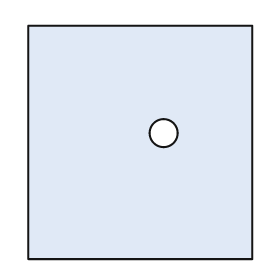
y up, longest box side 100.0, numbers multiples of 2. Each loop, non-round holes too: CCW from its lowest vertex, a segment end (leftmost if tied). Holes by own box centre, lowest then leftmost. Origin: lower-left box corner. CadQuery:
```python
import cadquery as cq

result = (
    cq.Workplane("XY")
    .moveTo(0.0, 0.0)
    .lineTo(96.0, 0.0)
    .lineTo(96.0, 100.0)
    .lineTo(0.0, 100.0)
    .close()
    .moveTo(58.0, 54.0)
    .circle(6.0)
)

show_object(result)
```